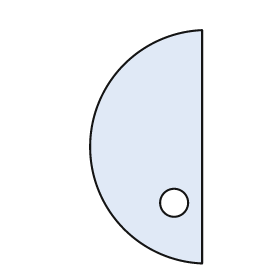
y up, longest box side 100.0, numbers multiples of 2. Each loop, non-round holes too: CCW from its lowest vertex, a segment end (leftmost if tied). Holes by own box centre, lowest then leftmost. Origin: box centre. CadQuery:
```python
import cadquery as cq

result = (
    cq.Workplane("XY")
    .moveTo(24.0, -50.0)
    .lineTo(24.0, 50.0)
    .threePointArc((-24.0, 0.0), (24.0, -50.0))
    .close()
    .moveTo(12.0, -24.0)
    .circle(6.0)
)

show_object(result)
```